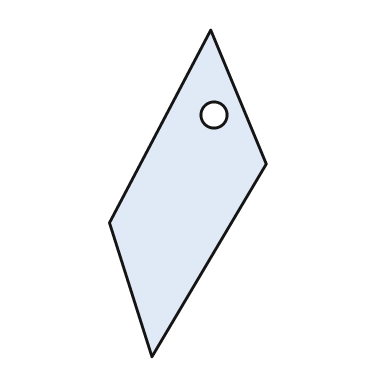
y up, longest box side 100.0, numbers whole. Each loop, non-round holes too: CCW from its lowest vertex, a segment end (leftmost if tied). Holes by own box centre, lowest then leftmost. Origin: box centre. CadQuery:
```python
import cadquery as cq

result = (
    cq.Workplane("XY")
    .moveTo(-11.0, -50.0)
    .lineTo(24.0, 9.0)
    .lineTo(7.0, 50.0)
    .lineTo(-24.0, -9.0)
    .close()
    .moveTo(8.0, 24.0)
    .circle(4.0)
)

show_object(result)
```